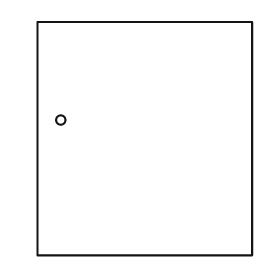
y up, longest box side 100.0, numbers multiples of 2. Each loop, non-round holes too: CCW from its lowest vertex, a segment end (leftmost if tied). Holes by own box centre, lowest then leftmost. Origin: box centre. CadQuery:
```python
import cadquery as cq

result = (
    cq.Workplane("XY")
    .moveTo(-46.0, -50.0)
    .lineTo(46.0, -50.0)
    .lineTo(46.0, 50.0)
    .lineTo(-46.0, 50.0)
    .close()
    .moveTo(-36.0, 8.0)
    .circle(2.0)
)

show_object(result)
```